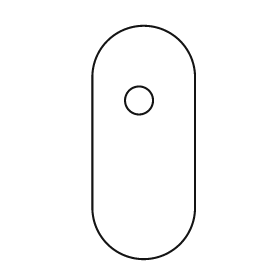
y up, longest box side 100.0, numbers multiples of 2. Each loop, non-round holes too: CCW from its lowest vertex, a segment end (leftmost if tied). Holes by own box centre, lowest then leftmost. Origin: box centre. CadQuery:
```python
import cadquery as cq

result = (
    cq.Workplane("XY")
    .moveTo(-22.0, -28.0)
    .threePointArc((0.0, -50.0), (22.0, -28.0))
    .lineTo(22.0, 28.0)
    .threePointArc((0.0, 50.0), (-22.0, 28.0))
    .close()
    .moveTo(-2.0, 18.0)
    .circle(6.0)
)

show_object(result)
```